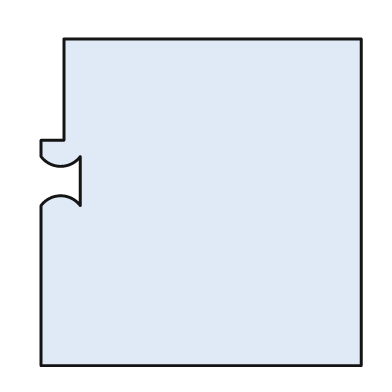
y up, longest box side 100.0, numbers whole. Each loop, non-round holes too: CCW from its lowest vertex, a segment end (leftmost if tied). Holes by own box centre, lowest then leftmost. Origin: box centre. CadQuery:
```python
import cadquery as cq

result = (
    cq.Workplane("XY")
    .moveTo(-49.0, -50.0)
    .lineTo(49.0, -50.0)
    .lineTo(49.0, 50.0)
    .lineTo(-42.0, 50.0)
    .lineTo(-42.0, 19.0)
    .lineTo(-49.0, 19.0)
    .lineTo(-49.0, 14.0)
    .threePointArc((-43.0, 11.0), (-37.0, 14.0))
    .lineTo(-37.0, -1.0)
    .threePointArc((-43.0, 2.0), (-49.0, -1.0))
    .close()
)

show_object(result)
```